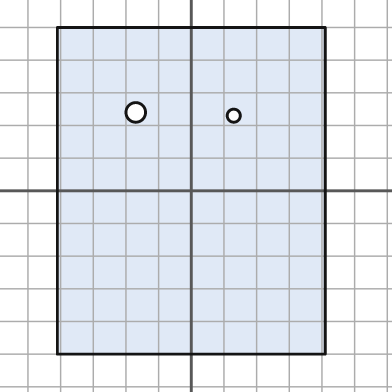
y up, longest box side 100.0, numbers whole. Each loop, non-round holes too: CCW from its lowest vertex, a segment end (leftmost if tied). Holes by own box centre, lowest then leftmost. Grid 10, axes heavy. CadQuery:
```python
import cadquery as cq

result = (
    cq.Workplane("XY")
    .moveTo(-41.0, -50.0)
    .lineTo(41.0, -50.0)
    .lineTo(41.0, 50.0)
    .lineTo(-41.0, 50.0)
    .close()
    .moveTo(13.0, 23.0)
    .circle(2.0)
    .moveTo(-17.0, 24.0)
    .circle(3.0)
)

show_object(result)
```